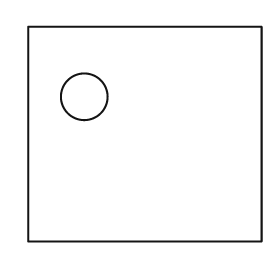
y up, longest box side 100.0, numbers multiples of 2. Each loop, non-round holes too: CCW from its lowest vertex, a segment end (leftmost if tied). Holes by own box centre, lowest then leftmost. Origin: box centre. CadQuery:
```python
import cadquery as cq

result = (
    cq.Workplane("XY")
    .moveTo(-50.0, -46.0)
    .lineTo(50.0, -46.0)
    .lineTo(50.0, 46.0)
    .lineTo(-50.0, 46.0)
    .close()
    .moveTo(-26.0, 16.0)
    .circle(10.0)
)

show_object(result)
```